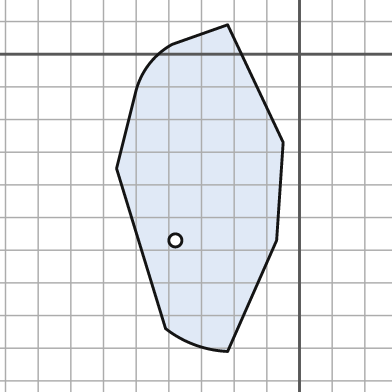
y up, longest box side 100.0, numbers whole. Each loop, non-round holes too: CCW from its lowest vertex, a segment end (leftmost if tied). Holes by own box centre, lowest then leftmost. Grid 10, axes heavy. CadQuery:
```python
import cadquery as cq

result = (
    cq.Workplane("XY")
    .moveTo(-22.0, -91.0)
    .lineTo(-7.0, -57.0)
    .lineTo(-5.0, -27.0)
    .lineTo(-22.0, 9.0)
    .lineTo(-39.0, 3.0)
    .threePointArc((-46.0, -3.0), (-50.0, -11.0))
    .lineTo(-56.0, -35.0)
    .lineTo(-41.0, -84.0)
    .threePointArc((-32.0, -89.0), (-22.0, -91.0))
    .close()
    .moveTo(-38.0, -57.0)
    .circle(2.0)
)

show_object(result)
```